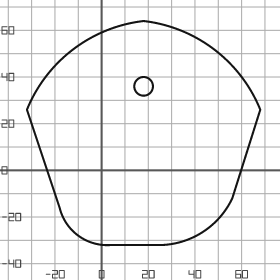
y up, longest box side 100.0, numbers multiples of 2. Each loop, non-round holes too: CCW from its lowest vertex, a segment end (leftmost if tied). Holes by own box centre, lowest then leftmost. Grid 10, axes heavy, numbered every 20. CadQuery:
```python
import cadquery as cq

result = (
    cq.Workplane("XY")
    .moveTo(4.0, -32.0)
    .lineTo(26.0, -32.0)
    .threePointArc((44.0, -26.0), (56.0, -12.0))
    .lineTo(68.0, 26.0)
    .threePointArc((48.0, 52.0), (18.0, 64.0))
    .threePointArc((-12.0, 52.0), (-32.0, 26.0))
    .lineTo(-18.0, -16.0)
    .threePointArc((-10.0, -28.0), (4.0, -32.0))
    .close()
    .moveTo(18.0, 36.0)
    .circle(4.0)
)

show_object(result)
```